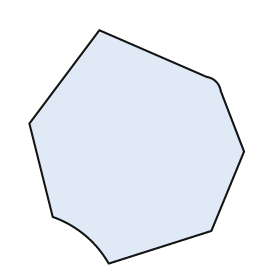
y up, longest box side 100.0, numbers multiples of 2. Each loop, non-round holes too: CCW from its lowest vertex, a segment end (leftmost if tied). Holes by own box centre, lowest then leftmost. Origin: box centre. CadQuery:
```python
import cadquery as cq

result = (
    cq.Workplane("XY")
    .moveTo(-12.0, -50.0)
    .lineTo(32.0, -36.0)
    .lineTo(46.0, -2.0)
    .lineTo(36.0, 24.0)
    .threePointArc((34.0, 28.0), (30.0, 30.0))
    .lineTo(-16.0, 50.0)
    .lineTo(-46.0, 10.0)
    .lineTo(-36.0, -30.0)
    .threePointArc((-22.0, -38.0), (-12.0, -50.0))
    .close()
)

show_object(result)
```